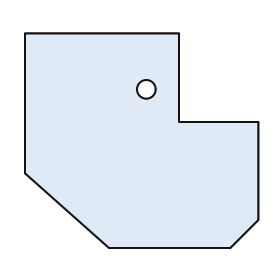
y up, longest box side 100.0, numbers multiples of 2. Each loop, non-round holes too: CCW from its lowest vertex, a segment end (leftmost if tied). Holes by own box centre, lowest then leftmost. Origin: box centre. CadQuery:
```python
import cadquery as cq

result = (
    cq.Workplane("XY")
    .moveTo(-14.0, -46.0)
    .lineTo(38.0, -46.0)
    .lineTo(50.0, -34.0)
    .lineTo(50.0, 8.0)
    .lineTo(16.0, 8.0)
    .lineTo(16.0, 46.0)
    .lineTo(-50.0, 46.0)
    .lineTo(-50.0, -14.0)
    .close()
    .moveTo(2.0, 22.0)
    .circle(4.0)
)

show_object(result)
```